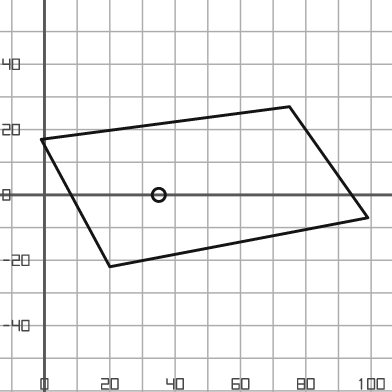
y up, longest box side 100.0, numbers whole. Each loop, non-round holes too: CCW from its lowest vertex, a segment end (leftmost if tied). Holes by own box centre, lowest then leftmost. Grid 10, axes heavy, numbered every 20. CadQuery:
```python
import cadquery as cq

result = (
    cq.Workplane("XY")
    .moveTo(20.0, -22.0)
    .lineTo(99.0, -7.0)
    .lineTo(75.0, 27.0)
    .lineTo(-1.0, 17.0)
    .close()
    .moveTo(35.0, 0.0)
    .circle(2.0)
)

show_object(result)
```